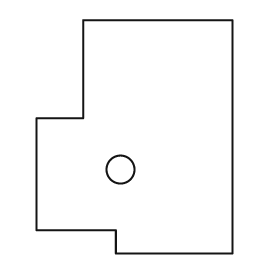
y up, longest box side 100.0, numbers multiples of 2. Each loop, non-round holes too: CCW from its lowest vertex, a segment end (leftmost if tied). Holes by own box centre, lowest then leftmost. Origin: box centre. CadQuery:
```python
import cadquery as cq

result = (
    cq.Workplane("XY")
    .moveTo(-8.0, -50.0)
    .lineTo(42.0, -50.0)
    .lineTo(42.0, 50.0)
    .lineTo(-22.0, 50.0)
    .lineTo(-22.0, 8.0)
    .lineTo(-42.0, 8.0)
    .lineTo(-42.0, -40.0)
    .lineTo(-8.0, -40.0)
    .close()
    .moveTo(-6.0, -14.0)
    .circle(6.0)
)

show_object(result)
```